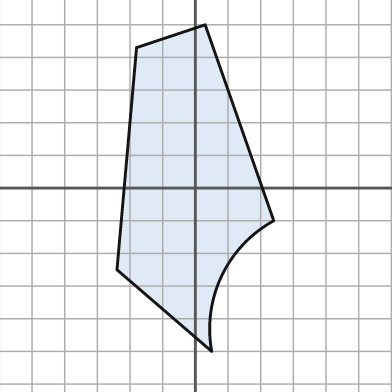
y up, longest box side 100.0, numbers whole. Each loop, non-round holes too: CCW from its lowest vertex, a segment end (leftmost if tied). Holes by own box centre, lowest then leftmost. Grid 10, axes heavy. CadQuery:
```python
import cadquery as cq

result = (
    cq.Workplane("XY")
    .moveTo(5.0, -50.0)
    .threePointArc((8.0, -27.0), (24.0, -10.0))
    .lineTo(3.0, 50.0)
    .lineTo(-18.0, 43.0)
    .lineTo(-24.0, -25.0)
    .close()
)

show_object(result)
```